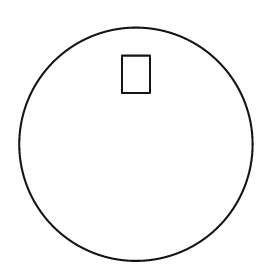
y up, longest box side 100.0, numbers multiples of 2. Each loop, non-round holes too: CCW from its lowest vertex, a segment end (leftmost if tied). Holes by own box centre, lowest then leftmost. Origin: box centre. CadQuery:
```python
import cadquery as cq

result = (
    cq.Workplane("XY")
    .moveTo(0.0, 0.0)
    .circle(50.0)
    .moveTo(-6.0, 22.0)
    .lineTo(6.0, 22.0)
    .lineTo(6.0, 38.0)
    .lineTo(-6.0, 38.0)
    .close()
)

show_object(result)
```